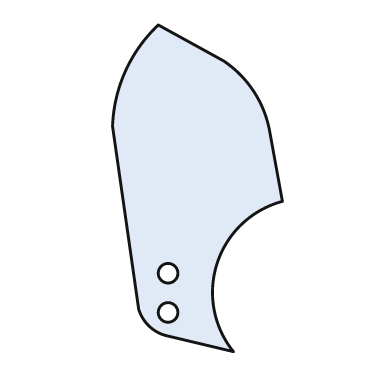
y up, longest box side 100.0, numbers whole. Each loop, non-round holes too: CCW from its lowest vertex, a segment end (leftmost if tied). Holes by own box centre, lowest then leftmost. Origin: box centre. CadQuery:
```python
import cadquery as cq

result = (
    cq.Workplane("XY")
    .moveTo(11.0, -50.0)
    .threePointArc((6.0, -23.0), (26.0, -4.0))
    .lineTo(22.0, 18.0)
    .threePointArc((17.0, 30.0), (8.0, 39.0))
    .lineTo(-12.0, 50.0)
    .threePointArc((-22.0, 36.0), (-26.0, 19.0))
    .lineTo(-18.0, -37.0)
    .threePointArc((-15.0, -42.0), (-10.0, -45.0))
    .close()
    .moveTo(-9.0, -38.0)
    .circle(3.0)
    .moveTo(-9.0, -26.0)
    .circle(3.0)
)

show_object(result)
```